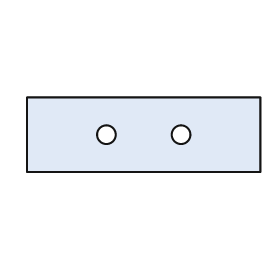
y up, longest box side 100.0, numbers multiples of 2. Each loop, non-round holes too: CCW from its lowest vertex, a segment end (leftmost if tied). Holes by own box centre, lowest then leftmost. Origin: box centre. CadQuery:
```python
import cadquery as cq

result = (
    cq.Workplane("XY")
    .moveTo(-50.0, -16.0)
    .lineTo(50.0, -16.0)
    .lineTo(50.0, 16.0)
    .lineTo(-50.0, 16.0)
    .close()
    .moveTo(-16.0, 0.0)
    .circle(4.0)
    .moveTo(16.0, 0.0)
    .circle(4.0)
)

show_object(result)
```